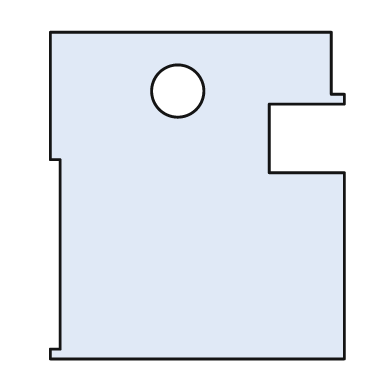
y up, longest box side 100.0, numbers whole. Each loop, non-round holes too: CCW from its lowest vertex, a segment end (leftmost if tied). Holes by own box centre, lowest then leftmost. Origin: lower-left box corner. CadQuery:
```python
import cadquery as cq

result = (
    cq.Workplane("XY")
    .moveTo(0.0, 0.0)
    .lineTo(90.0, 0.0)
    .lineTo(90.0, 57.0)
    .lineTo(67.0, 57.0)
    .lineTo(67.0, 78.0)
    .lineTo(90.0, 78.0)
    .lineTo(90.0, 81.0)
    .lineTo(86.0, 81.0)
    .lineTo(86.0, 100.0)
    .lineTo(0.0, 100.0)
    .lineTo(0.0, 61.0)
    .lineTo(3.0, 61.0)
    .lineTo(3.0, 3.0)
    .lineTo(0.0, 3.0)
    .close()
    .moveTo(39.0, 82.0)
    .circle(8.0)
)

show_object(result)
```